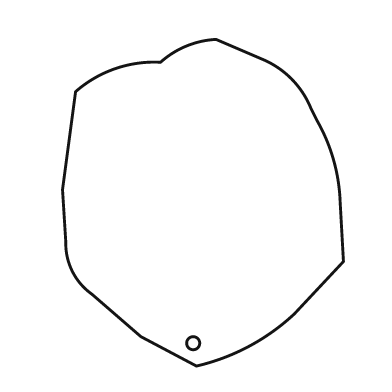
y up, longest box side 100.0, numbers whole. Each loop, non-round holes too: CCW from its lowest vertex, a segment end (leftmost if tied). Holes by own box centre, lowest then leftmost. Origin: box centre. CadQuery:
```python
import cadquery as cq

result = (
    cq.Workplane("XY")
    .moveTo(-2.0, -50.0)
    .threePointArc((14.0, -44.0), (28.0, -34.0))
    .lineTo(43.0, -18.0)
    .lineTo(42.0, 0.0)
    .threePointArc((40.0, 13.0), (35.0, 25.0))
    .lineTo(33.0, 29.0)
    .threePointArc((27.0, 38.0), (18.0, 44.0))
    .lineTo(4.0, 50.0)
    .threePointArc((-5.0, 48.0), (-13.0, 43.0))
    .threePointArc((-27.0, 41.0), (-39.0, 34.0))
    .lineTo(-43.0, 4.0)
    .lineTo(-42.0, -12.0)
    .threePointArc((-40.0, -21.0), (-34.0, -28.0))
    .lineTo(-19.0, -41.0)
    .close()
    .moveTo(-3.0, -43.0)
    .circle(2.0)
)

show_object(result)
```